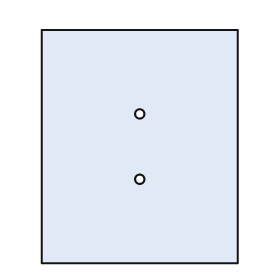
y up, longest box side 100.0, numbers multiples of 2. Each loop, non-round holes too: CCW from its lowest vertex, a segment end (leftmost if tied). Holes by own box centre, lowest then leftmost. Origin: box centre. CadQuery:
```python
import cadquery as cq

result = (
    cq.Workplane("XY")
    .moveTo(-42.0, -50.0)
    .lineTo(42.0, -50.0)
    .lineTo(42.0, 50.0)
    .lineTo(-42.0, 50.0)
    .close()
    .moveTo(0.0, -14.0)
    .circle(2.0)
    .moveTo(0.0, 14.0)
    .circle(2.0)
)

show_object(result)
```